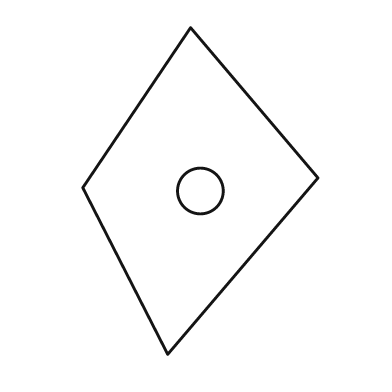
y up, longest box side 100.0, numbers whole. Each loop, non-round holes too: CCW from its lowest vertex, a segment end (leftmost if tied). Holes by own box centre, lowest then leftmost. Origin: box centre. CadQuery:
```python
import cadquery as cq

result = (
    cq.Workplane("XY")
    .moveTo(-10.0, -50.0)
    .lineTo(36.0, 4.0)
    .lineTo(-3.0, 50.0)
    .lineTo(-36.0, 1.0)
    .close()
    .moveTo(0.0, 0.0)
    .circle(7.0)
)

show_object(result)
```